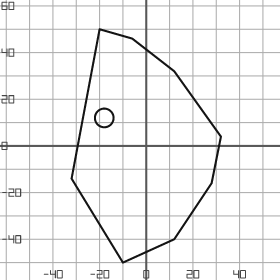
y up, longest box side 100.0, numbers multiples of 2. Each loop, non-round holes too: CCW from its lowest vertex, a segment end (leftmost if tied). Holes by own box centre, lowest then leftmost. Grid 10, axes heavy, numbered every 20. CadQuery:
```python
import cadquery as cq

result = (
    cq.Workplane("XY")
    .moveTo(-10.0, -50.0)
    .lineTo(12.0, -40.0)
    .lineTo(28.0, -16.0)
    .lineTo(32.0, 4.0)
    .lineTo(12.0, 32.0)
    .lineTo(-6.0, 46.0)
    .lineTo(-20.0, 50.0)
    .lineTo(-32.0, -14.0)
    .close()
    .moveTo(-18.0, 12.0)
    .circle(4.0)
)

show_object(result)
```